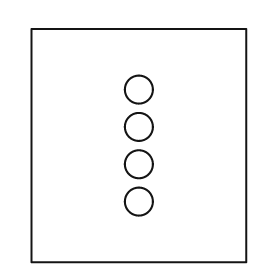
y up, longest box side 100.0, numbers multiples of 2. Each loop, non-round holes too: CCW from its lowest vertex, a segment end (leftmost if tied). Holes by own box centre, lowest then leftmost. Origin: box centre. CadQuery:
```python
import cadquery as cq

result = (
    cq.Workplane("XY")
    .moveTo(-46.0, -50.0)
    .lineTo(46.0, -50.0)
    .lineTo(46.0, 50.0)
    .lineTo(-46.0, 50.0)
    .close()
    .moveTo(0.0, -24.0)
    .circle(6.0)
    .moveTo(0.0, -8.0)
    .circle(6.0)
    .moveTo(0.0, 8.0)
    .circle(6.0)
    .moveTo(0.0, 24.0)
    .circle(6.0)
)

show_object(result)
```